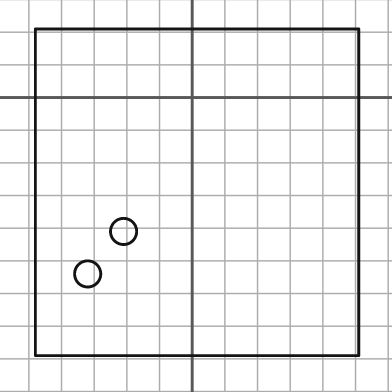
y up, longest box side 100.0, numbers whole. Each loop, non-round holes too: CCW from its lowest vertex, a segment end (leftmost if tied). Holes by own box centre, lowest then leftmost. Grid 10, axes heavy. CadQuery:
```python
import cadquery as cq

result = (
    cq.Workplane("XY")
    .moveTo(-48.0, -79.0)
    .lineTo(51.0, -79.0)
    .lineTo(51.0, 21.0)
    .lineTo(-48.0, 21.0)
    .close()
    .moveTo(-32.0, -54.0)
    .circle(4.0)
    .moveTo(-21.0, -41.0)
    .circle(4.0)
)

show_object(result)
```